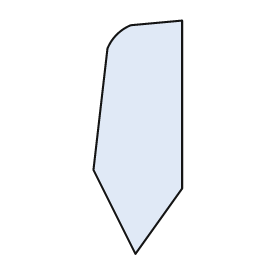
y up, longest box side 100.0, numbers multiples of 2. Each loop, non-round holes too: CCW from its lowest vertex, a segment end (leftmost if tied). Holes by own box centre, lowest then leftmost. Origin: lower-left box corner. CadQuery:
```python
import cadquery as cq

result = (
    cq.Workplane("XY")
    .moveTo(18.0, 0.0)
    .lineTo(38.0, 28.0)
    .lineTo(38.0, 100.0)
    .lineTo(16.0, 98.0)
    .threePointArc((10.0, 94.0), (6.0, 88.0))
    .lineTo(0.0, 36.0)
    .close()
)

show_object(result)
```